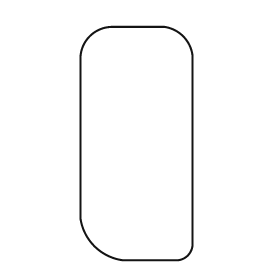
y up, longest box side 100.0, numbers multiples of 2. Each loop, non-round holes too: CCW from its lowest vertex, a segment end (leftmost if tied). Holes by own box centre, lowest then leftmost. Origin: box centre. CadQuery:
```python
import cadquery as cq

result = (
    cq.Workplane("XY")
    .moveTo(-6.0, -50.0)
    .lineTo(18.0, -50.0)
    .threePointArc((22.0, -48.0), (24.0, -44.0))
    .lineTo(24.0, 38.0)
    .threePointArc((20.0, 46.0), (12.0, 50.0))
    .lineTo(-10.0, 50.0)
    .threePointArc((-20.0, 46.0), (-24.0, 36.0))
    .lineTo(-24.0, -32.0)
    .threePointArc((-18.0, -44.0), (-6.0, -50.0))
    .close()
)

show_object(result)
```